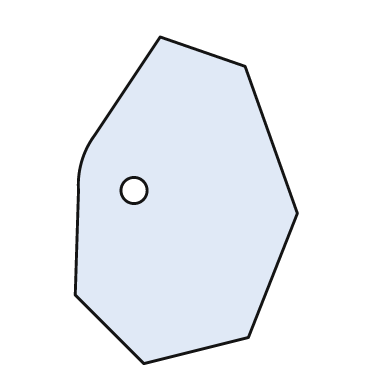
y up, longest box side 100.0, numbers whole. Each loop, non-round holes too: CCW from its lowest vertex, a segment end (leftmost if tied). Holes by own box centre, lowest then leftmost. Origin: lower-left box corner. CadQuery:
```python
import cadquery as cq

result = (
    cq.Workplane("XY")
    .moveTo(21.0, 0.0)
    .lineTo(53.0, 8.0)
    .lineTo(68.0, 46.0)
    .lineTo(52.0, 91.0)
    .lineTo(26.0, 100.0)
    .lineTo(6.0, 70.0)
    .threePointArc((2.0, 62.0), (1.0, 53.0))
    .lineTo(0.0, 21.0)
    .close()
    .moveTo(18.0, 53.0)
    .circle(4.0)
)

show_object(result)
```